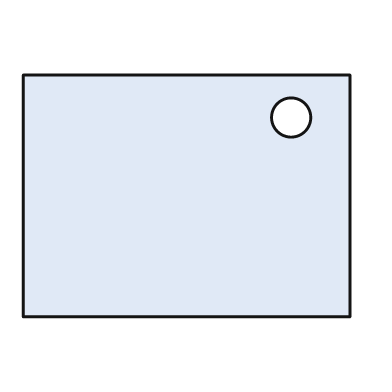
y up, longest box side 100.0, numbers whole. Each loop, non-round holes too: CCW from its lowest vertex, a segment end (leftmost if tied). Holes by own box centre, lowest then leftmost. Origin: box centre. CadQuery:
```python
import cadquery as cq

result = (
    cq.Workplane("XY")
    .moveTo(-50.0, -37.0)
    .lineTo(50.0, -37.0)
    .lineTo(50.0, 37.0)
    .lineTo(-50.0, 37.0)
    .close()
    .moveTo(32.0, 24.0)
    .circle(6.0)
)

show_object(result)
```